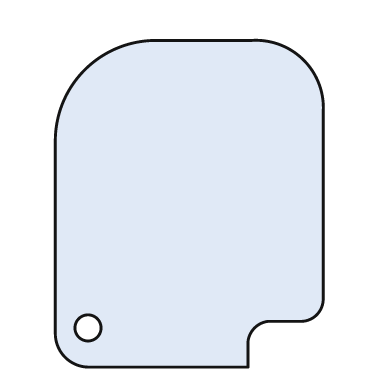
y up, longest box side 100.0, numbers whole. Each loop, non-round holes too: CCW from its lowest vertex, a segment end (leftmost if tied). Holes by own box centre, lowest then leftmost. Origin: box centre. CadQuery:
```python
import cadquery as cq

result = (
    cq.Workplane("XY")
    .moveTo(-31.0, -50.0)
    .lineTo(18.0, -50.0)
    .lineTo(18.0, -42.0)
    .threePointArc((20.0, -38.0), (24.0, -36.0))
    .lineTo(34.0, -36.0)
    .threePointArc((39.0, -34.0), (41.0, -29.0))
    .lineTo(41.0, 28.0)
    .threePointArc((35.0, 44.0), (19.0, 50.0))
    .lineTo(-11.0, 50.0)
    .threePointArc((-32.0, 41.0), (-41.0, 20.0))
    .lineTo(-41.0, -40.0)
    .threePointArc((-38.0, -47.0), (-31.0, -50.0))
    .close()
    .moveTo(-31.0, -38.0)
    .circle(4.0)
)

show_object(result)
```